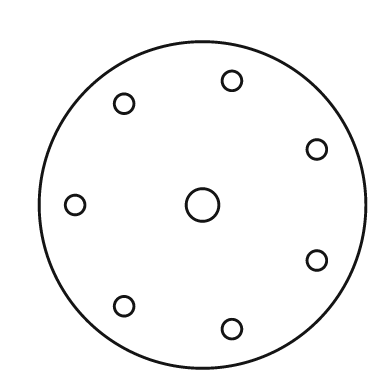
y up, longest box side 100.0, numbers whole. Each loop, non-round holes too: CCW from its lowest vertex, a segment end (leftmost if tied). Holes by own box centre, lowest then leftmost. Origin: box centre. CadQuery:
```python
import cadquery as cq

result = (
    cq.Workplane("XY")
    .moveTo(0.0, 0.0)
    .circle(50.0)
    .moveTo(9.0, -38.0)
    .circle(3.0)
    .moveTo(-24.0, -31.0)
    .circle(3.0)
    .moveTo(35.0, -17.0)
    .circle(3.0)
    .moveTo(-39.0, 0.0)
    .circle(3.0)
    .moveTo(0.0, 0.0)
    .circle(5.0)
    .moveTo(35.0, 17.0)
    .circle(3.0)
    .moveTo(-24.0, 31.0)
    .circle(3.0)
    .moveTo(9.0, 38.0)
    .circle(3.0)
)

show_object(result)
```